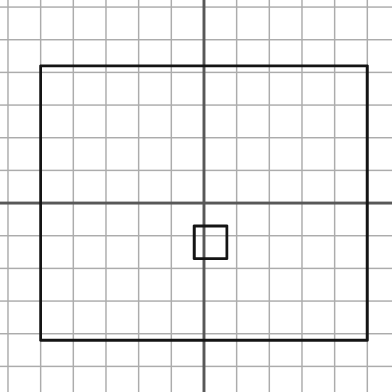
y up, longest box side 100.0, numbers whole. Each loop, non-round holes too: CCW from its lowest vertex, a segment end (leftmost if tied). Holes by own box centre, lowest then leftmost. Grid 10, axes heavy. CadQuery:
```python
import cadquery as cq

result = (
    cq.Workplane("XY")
    .moveTo(-50.0, -42.0)
    .lineTo(50.0, -42.0)
    .lineTo(50.0, 42.0)
    .lineTo(-50.0, 42.0)
    .close()
    .moveTo(-3.0, -17.0)
    .lineTo(7.0, -17.0)
    .lineTo(7.0, -7.0)
    .lineTo(-3.0, -7.0)
    .close()
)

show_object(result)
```